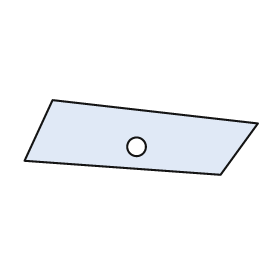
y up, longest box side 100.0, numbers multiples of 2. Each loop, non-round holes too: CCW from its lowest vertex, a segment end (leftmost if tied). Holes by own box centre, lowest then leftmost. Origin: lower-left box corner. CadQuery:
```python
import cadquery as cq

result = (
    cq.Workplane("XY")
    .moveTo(84.0, 0.0)
    .lineTo(100.0, 22.0)
    .lineTo(12.0, 32.0)
    .lineTo(0.0, 6.0)
    .close()
    .moveTo(48.0, 12.0)
    .circle(4.0)
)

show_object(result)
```